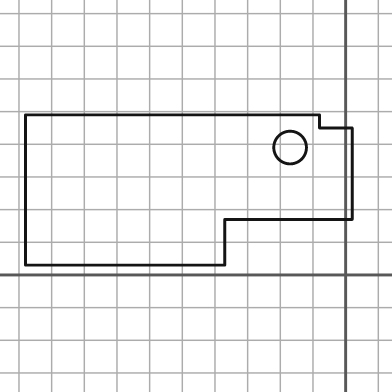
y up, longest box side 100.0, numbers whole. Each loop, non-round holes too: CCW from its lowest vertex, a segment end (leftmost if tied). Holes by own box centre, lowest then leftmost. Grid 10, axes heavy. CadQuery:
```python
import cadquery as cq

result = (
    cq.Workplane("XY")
    .moveTo(-98.0, 3.0)
    .lineTo(-37.0, 3.0)
    .lineTo(-37.0, 17.0)
    .lineTo(2.0, 17.0)
    .lineTo(2.0, 45.0)
    .lineTo(-8.0, 45.0)
    .lineTo(-8.0, 49.0)
    .lineTo(-98.0, 49.0)
    .close()
    .moveTo(-17.0, 39.0)
    .circle(5.0)
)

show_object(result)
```